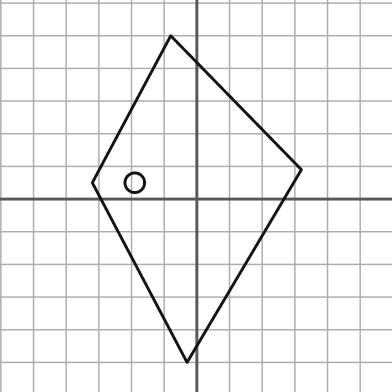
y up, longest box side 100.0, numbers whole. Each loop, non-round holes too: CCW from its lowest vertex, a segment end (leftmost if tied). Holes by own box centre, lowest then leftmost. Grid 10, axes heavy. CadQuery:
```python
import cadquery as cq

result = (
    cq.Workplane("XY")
    .moveTo(-3.0, -50.0)
    .lineTo(32.0, 9.0)
    .lineTo(-8.0, 50.0)
    .lineTo(-32.0, 5.0)
    .close()
    .moveTo(-19.0, 5.0)
    .circle(3.0)
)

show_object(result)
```